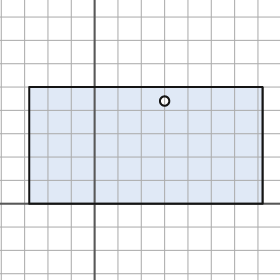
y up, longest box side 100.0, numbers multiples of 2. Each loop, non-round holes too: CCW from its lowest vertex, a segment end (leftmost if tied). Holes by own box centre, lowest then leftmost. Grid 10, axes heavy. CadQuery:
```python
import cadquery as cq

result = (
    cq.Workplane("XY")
    .moveTo(-28.0, 0.0)
    .lineTo(72.0, 0.0)
    .lineTo(72.0, 50.0)
    .lineTo(-28.0, 50.0)
    .close()
    .moveTo(30.0, 44.0)
    .circle(2.0)
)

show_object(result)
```